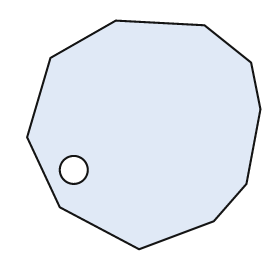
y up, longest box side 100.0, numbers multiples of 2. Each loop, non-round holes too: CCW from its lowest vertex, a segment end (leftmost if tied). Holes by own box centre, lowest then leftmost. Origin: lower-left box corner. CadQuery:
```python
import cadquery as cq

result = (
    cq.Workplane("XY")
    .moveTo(48.0, 0.0)
    .lineTo(80.0, 12.0)
    .lineTo(94.0, 28.0)
    .lineTo(100.0, 60.0)
    .lineTo(96.0, 80.0)
    .lineTo(76.0, 96.0)
    .lineTo(38.0, 98.0)
    .lineTo(10.0, 82.0)
    .lineTo(0.0, 48.0)
    .lineTo(14.0, 18.0)
    .close()
    .moveTo(20.0, 34.0)
    .circle(6.0)
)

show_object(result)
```